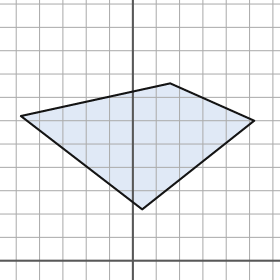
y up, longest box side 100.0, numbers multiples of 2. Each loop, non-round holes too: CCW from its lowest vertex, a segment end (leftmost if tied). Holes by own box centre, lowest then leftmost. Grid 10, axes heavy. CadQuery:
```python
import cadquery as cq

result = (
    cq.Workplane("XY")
    .moveTo(4.0, 22.0)
    .lineTo(52.0, 60.0)
    .lineTo(16.0, 76.0)
    .lineTo(-48.0, 62.0)
    .close()
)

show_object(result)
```